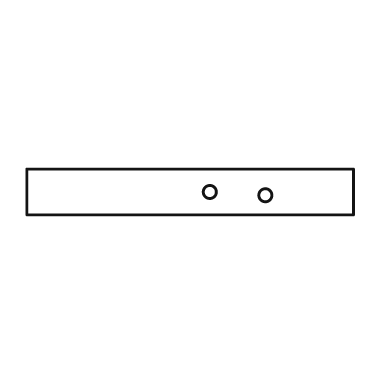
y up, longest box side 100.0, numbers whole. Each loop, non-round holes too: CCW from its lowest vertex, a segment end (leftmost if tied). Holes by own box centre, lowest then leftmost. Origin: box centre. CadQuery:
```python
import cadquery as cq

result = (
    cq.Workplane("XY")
    .moveTo(-50.0, -7.0)
    .lineTo(50.0, -7.0)
    .lineTo(50.0, 7.0)
    .lineTo(-50.0, 7.0)
    .close()
    .moveTo(23.0, -1.0)
    .circle(2.0)
    .moveTo(6.0, 0.0)
    .circle(2.0)
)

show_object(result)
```